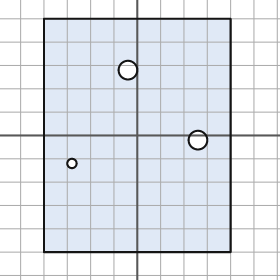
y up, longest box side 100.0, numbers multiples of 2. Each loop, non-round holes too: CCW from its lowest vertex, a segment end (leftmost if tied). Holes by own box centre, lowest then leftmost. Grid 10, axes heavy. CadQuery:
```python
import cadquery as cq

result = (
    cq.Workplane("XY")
    .moveTo(-40.0, -50.0)
    .lineTo(40.0, -50.0)
    .lineTo(40.0, 50.0)
    .lineTo(-40.0, 50.0)
    .close()
    .moveTo(-28.0, -12.0)
    .circle(2.0)
    .moveTo(26.0, -2.0)
    .circle(4.0)
    .moveTo(-4.0, 28.0)
    .circle(4.0)
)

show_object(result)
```